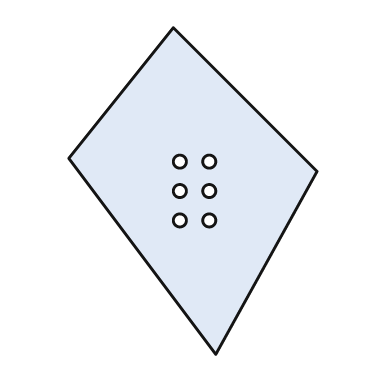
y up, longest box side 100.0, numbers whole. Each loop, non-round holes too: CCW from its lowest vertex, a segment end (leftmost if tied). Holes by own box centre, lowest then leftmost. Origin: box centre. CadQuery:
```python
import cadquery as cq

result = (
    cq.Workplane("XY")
    .moveTo(7.0, -50.0)
    .lineTo(38.0, 6.0)
    .lineTo(-6.0, 50.0)
    .lineTo(-38.0, 10.0)
    .close()
    .moveTo(-4.0, -9.0)
    .circle(2.0)
    .moveTo(5.0, -9.0)
    .circle(2.0)
    .moveTo(-4.0, 0.0)
    .circle(2.0)
    .moveTo(5.0, 0.0)
    .circle(2.0)
    .moveTo(-4.0, 9.0)
    .circle(2.0)
    .moveTo(5.0, 9.0)
    .circle(2.0)
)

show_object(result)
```